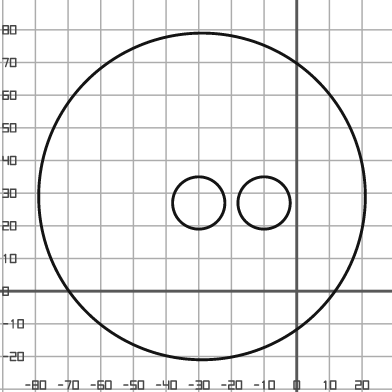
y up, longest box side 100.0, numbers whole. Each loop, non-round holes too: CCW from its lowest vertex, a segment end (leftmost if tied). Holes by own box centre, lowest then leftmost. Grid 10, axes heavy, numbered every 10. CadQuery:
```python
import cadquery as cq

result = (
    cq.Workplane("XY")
    .moveTo(-29.0, 29.0)
    .circle(50.0)
    .moveTo(-30.0, 27.0)
    .circle(8.0)
    .moveTo(-10.0, 27.0)
    .circle(8.0)
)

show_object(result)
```